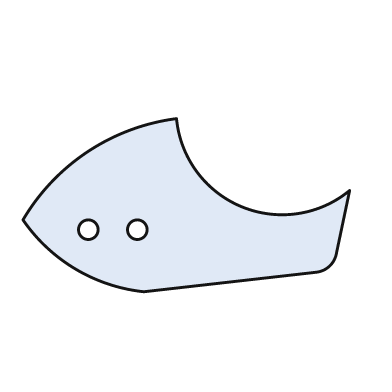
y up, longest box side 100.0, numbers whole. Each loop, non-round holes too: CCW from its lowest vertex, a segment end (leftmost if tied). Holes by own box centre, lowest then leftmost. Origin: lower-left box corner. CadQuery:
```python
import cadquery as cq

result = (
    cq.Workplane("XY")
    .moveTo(37.0, 0.0)
    .lineTo(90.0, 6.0)
    .threePointArc((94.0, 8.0), (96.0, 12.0))
    .lineTo(100.0, 31.0)
    .threePointArc((67.0, 26.0), (47.0, 53.0))
    .threePointArc((20.0, 43.0), (0.0, 22.0))
    .threePointArc((16.0, 7.0), (37.0, 0.0))
    .close()
    .moveTo(20.0, 19.0)
    .circle(3.0)
    .moveTo(35.0, 19.0)
    .circle(3.0)
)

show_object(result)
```